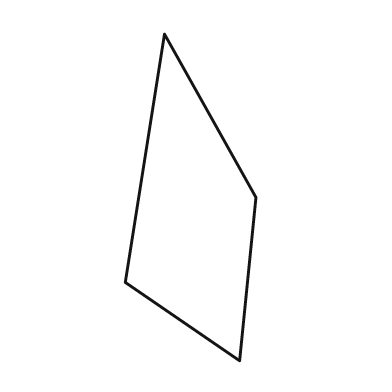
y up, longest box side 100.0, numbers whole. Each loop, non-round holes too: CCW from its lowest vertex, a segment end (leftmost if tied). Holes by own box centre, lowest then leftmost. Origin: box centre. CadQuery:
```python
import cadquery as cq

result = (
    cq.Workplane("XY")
    .moveTo(15.0, -50.0)
    .lineTo(20.0, 0.0)
    .lineTo(-8.0, 50.0)
    .lineTo(-20.0, -26.0)
    .close()
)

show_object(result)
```